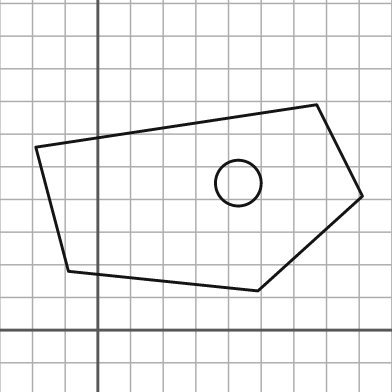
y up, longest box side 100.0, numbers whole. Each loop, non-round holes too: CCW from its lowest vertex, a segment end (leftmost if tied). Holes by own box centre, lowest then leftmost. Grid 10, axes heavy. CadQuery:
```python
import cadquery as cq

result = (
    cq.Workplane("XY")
    .moveTo(49.0, 12.0)
    .lineTo(81.0, 41.0)
    .lineTo(67.0, 69.0)
    .lineTo(-19.0, 56.0)
    .lineTo(-9.0, 18.0)
    .close()
    .moveTo(43.0, 45.0)
    .circle(7.0)
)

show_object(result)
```